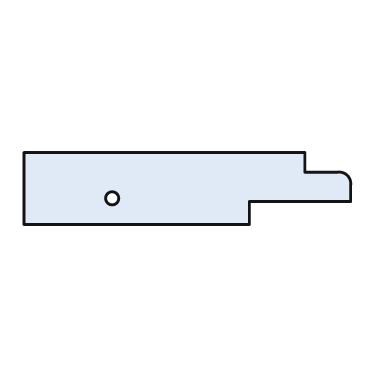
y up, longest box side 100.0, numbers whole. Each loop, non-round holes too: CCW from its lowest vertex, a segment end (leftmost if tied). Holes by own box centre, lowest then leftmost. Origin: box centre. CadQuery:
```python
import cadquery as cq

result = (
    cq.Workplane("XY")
    .moveTo(-50.0, -11.0)
    .lineTo(19.0, -11.0)
    .lineTo(19.0, -4.0)
    .lineTo(50.0, -4.0)
    .lineTo(50.0, 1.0)
    .threePointArc((49.0, 4.0), (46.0, 5.0))
    .lineTo(36.0, 5.0)
    .lineTo(36.0, 11.0)
    .lineTo(-50.0, 11.0)
    .close()
    .moveTo(-23.0, -3.0)
    .circle(2.0)
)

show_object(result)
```